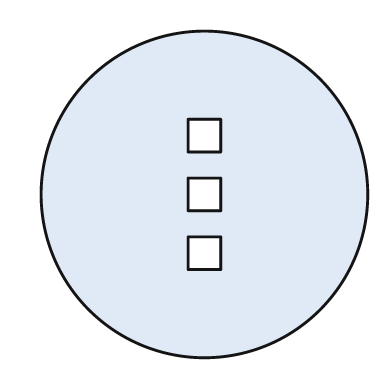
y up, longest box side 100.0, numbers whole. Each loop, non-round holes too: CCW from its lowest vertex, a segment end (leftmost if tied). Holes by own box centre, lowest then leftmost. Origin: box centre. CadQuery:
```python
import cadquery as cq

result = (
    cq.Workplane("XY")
    .moveTo(0.0, 0.0)
    .circle(50.0)
    .moveTo(-5.0, -23.0)
    .lineTo(5.0, -23.0)
    .lineTo(5.0, -13.0)
    .lineTo(-5.0, -13.0)
    .close()
    .moveTo(-5.0, -5.0)
    .lineTo(5.0, -5.0)
    .lineTo(5.0, 5.0)
    .lineTo(-5.0, 5.0)
    .close()
    .moveTo(-5.0, 13.0)
    .lineTo(5.0, 13.0)
    .lineTo(5.0, 23.0)
    .lineTo(-5.0, 23.0)
    .close()
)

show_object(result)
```